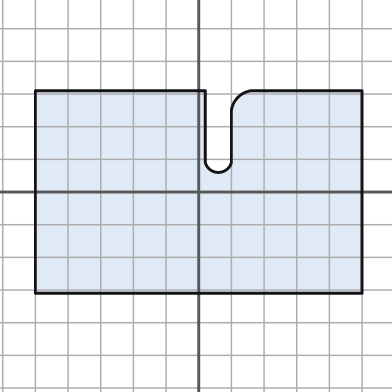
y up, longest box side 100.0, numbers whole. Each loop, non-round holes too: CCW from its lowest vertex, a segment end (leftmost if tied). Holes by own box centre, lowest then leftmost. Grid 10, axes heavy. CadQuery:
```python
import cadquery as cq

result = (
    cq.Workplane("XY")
    .moveTo(-50.0, -31.0)
    .lineTo(50.0, -31.0)
    .lineTo(50.0, 31.0)
    .lineTo(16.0, 31.0)
    .threePointArc((12.0, 29.0), (10.0, 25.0))
    .lineTo(10.0, 9.0)
    .threePointArc((6.0, 6.0), (2.0, 9.0))
    .lineTo(2.0, 31.0)
    .lineTo(-50.0, 31.0)
    .close()
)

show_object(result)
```